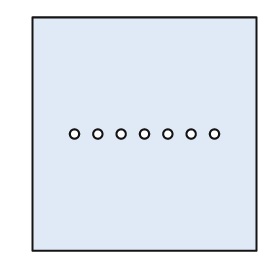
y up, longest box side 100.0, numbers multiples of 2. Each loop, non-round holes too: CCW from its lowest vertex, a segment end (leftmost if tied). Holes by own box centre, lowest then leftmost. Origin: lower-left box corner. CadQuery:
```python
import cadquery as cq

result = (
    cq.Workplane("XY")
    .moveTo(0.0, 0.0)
    .lineTo(96.0, 0.0)
    .lineTo(96.0, 100.0)
    .lineTo(0.0, 100.0)
    .close()
    .moveTo(18.0, 50.0)
    .circle(2.0)
    .moveTo(28.0, 50.0)
    .circle(2.0)
    .moveTo(38.0, 50.0)
    .circle(2.0)
    .moveTo(48.0, 50.0)
    .circle(2.0)
    .moveTo(58.0, 50.0)
    .circle(2.0)
    .moveTo(68.0, 50.0)
    .circle(2.0)
    .moveTo(78.0, 50.0)
    .circle(2.0)
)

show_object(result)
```